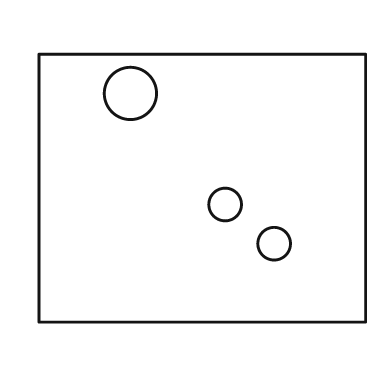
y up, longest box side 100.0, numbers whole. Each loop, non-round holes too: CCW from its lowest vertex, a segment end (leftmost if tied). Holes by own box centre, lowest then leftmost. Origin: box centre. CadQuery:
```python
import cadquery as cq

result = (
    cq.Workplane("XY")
    .moveTo(-50.0, -41.0)
    .lineTo(50.0, -41.0)
    .lineTo(50.0, 41.0)
    .lineTo(-50.0, 41.0)
    .close()
    .moveTo(22.0, -17.0)
    .circle(5.0)
    .moveTo(7.0, -5.0)
    .circle(5.0)
    .moveTo(-22.0, 29.0)
    .circle(8.0)
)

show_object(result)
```